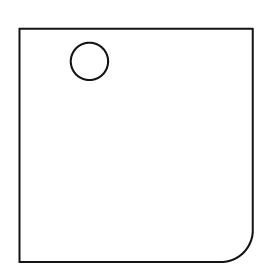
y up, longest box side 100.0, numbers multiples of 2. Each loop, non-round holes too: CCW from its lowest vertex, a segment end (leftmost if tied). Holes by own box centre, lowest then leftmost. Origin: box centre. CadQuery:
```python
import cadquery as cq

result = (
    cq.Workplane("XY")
    .moveTo(-50.0, -50.0)
    .lineTo(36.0, -50.0)
    .threePointArc((46.0, -46.0), (50.0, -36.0))
    .lineTo(50.0, 50.0)
    .lineTo(-50.0, 50.0)
    .close()
    .moveTo(-20.0, 36.0)
    .circle(8.0)
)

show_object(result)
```